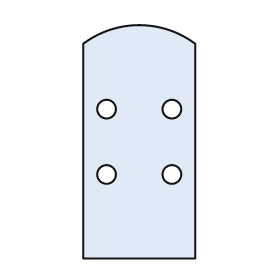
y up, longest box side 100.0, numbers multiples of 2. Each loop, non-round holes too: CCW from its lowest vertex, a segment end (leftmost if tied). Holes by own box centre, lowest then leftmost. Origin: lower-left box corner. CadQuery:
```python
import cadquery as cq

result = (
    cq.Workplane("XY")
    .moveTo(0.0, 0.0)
    .lineTo(48.0, 0.0)
    .lineTo(48.0, 92.0)
    .threePointArc((24.0, 100.0), (0.0, 92.0))
    .close()
    .moveTo(10.0, 36.0)
    .circle(4.0)
    .moveTo(38.0, 36.0)
    .circle(4.0)
    .moveTo(10.0, 64.0)
    .circle(4.0)
    .moveTo(38.0, 64.0)
    .circle(4.0)
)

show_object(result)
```